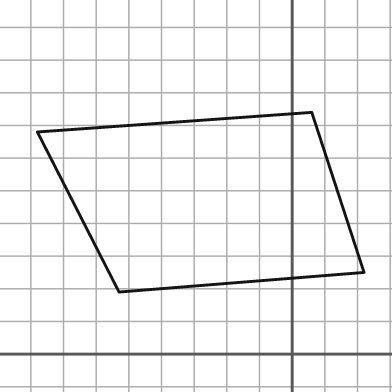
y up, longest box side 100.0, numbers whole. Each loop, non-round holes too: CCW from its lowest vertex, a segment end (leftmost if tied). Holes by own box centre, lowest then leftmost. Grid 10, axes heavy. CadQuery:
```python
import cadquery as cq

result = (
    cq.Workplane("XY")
    .moveTo(-53.0, 19.0)
    .lineTo(22.0, 25.0)
    .lineTo(6.0, 74.0)
    .lineTo(-78.0, 68.0)
    .close()
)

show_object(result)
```